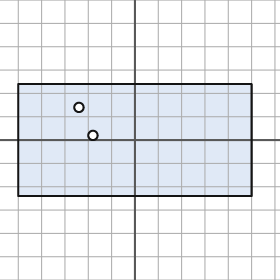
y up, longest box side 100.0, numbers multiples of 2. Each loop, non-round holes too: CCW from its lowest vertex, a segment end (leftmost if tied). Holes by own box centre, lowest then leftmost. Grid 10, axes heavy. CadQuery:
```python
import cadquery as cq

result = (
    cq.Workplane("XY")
    .moveTo(-50.0, -24.0)
    .lineTo(50.0, -24.0)
    .lineTo(50.0, 24.0)
    .lineTo(-50.0, 24.0)
    .close()
    .moveTo(-18.0, 2.0)
    .circle(2.0)
    .moveTo(-24.0, 14.0)
    .circle(2.0)
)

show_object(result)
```